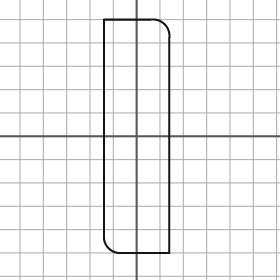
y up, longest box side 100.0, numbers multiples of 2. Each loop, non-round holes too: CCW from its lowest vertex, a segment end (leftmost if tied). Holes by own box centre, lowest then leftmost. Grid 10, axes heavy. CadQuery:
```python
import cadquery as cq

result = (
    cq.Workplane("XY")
    .moveTo(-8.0, -50.0)
    .lineTo(14.0, -50.0)
    .lineTo(14.0, 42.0)
    .threePointArc((12.0, 48.0), (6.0, 50.0))
    .lineTo(-14.0, 50.0)
    .lineTo(-14.0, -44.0)
    .threePointArc((-12.0, -48.0), (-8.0, -50.0))
    .close()
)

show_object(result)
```